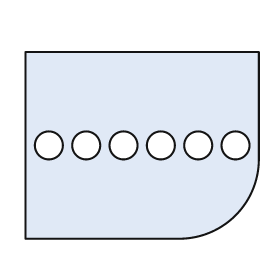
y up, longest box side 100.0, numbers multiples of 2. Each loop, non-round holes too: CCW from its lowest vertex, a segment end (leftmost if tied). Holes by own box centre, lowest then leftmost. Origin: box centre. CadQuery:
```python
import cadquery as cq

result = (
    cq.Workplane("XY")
    .moveTo(-50.0, -40.0)
    .lineTo(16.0, -40.0)
    .threePointArc((40.0, -30.0), (50.0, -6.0))
    .lineTo(50.0, 40.0)
    .lineTo(-50.0, 40.0)
    .close()
    .moveTo(-40.0, 0.0)
    .circle(6.0)
    .moveTo(-24.0, 0.0)
    .circle(6.0)
    .moveTo(-8.0, 0.0)
    .circle(6.0)
    .moveTo(8.0, 0.0)
    .circle(6.0)
    .moveTo(24.0, 0.0)
    .circle(6.0)
    .moveTo(40.0, 0.0)
    .circle(6.0)
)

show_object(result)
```